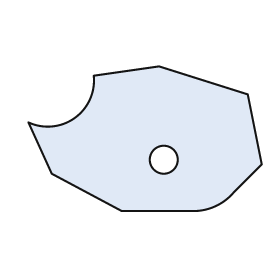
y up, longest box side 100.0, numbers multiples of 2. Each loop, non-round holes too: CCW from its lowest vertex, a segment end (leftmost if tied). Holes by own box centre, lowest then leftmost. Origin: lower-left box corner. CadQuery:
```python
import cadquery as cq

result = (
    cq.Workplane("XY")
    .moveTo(40.0, 0.0)
    .lineTo(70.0, 0.0)
    .threePointArc((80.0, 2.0), (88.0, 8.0))
    .lineTo(100.0, 20.0)
    .lineTo(94.0, 50.0)
    .lineTo(56.0, 62.0)
    .lineTo(28.0, 58.0)
    .threePointArc((20.0, 40.0), (0.0, 38.0))
    .lineTo(10.0, 16.0)
    .close()
    .moveTo(58.0, 22.0)
    .circle(6.0)
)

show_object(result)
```